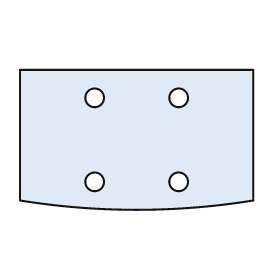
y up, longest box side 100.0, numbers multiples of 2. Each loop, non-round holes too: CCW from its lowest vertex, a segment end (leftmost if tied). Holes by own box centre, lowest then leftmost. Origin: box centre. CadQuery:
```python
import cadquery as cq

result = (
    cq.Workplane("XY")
    .moveTo(-50.0, -26.0)
    .threePointArc((0.0, -30.0), (50.0, -26.0))
    .lineTo(50.0, 30.0)
    .lineTo(-50.0, 30.0)
    .close()
    .moveTo(-18.0, -18.0)
    .circle(4.0)
    .moveTo(18.0, -18.0)
    .circle(4.0)
    .moveTo(-18.0, 18.0)
    .circle(4.0)
    .moveTo(18.0, 18.0)
    .circle(4.0)
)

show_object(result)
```